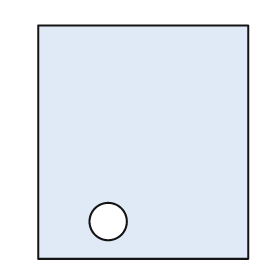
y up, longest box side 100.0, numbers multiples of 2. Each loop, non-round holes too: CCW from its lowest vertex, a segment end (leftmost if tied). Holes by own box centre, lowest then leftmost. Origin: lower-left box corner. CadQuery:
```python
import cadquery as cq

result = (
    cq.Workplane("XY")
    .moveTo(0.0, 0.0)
    .lineTo(90.0, 0.0)
    .lineTo(90.0, 100.0)
    .lineTo(0.0, 100.0)
    .close()
    .moveTo(30.0, 16.0)
    .circle(8.0)
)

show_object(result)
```